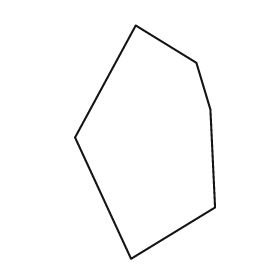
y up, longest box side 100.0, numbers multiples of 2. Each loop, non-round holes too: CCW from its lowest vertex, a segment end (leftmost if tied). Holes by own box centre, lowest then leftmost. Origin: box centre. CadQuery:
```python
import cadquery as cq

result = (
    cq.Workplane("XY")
    .moveTo(-6.0, -50.0)
    .lineTo(30.0, -28.0)
    .lineTo(28.0, 14.0)
    .lineTo(22.0, 34.0)
    .lineTo(-4.0, 50.0)
    .lineTo(-30.0, 2.0)
    .close()
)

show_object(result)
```